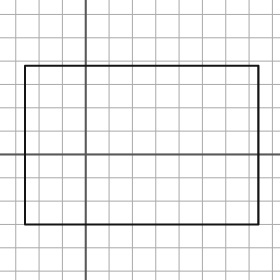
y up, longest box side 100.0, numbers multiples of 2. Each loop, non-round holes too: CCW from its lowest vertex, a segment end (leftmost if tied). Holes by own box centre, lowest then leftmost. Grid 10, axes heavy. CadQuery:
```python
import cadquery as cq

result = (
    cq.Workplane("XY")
    .moveTo(-26.0, -30.0)
    .lineTo(74.0, -30.0)
    .lineTo(74.0, 38.0)
    .lineTo(-26.0, 38.0)
    .close()
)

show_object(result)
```